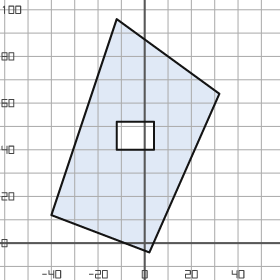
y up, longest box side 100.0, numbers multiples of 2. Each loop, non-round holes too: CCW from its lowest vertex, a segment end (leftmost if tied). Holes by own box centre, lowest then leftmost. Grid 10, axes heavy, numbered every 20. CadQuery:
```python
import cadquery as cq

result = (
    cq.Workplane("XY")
    .moveTo(2.0, -4.0)
    .lineTo(32.0, 64.0)
    .lineTo(-12.0, 96.0)
    .lineTo(-40.0, 12.0)
    .close()
    .moveTo(-12.0, 40.0)
    .lineTo(4.0, 40.0)
    .lineTo(4.0, 52.0)
    .lineTo(-12.0, 52.0)
    .close()
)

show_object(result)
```